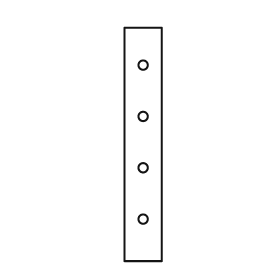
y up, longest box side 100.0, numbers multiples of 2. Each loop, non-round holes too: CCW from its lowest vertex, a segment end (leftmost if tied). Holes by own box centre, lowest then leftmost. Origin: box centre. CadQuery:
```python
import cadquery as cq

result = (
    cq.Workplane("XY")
    .moveTo(-8.0, -50.0)
    .lineTo(8.0, -50.0)
    .lineTo(8.0, 50.0)
    .lineTo(-8.0, 50.0)
    .close()
    .moveTo(0.0, -32.0)
    .circle(2.0)
    .moveTo(0.0, -10.0)
    .circle(2.0)
    .moveTo(0.0, 12.0)
    .circle(2.0)
    .moveTo(0.0, 34.0)
    .circle(2.0)
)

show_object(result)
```